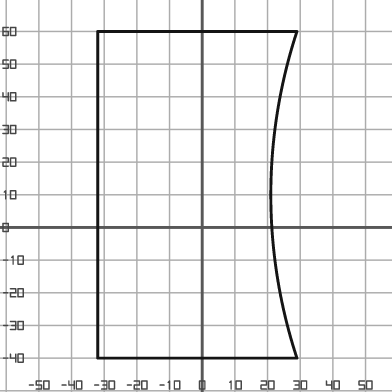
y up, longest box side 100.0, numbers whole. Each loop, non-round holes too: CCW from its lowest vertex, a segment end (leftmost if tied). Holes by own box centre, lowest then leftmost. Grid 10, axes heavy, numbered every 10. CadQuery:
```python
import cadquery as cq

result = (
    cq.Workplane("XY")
    .moveTo(-32.0, -40.0)
    .lineTo(29.0, -40.0)
    .threePointArc((21.0, 10.0), (29.0, 60.0))
    .lineTo(-32.0, 60.0)
    .close()
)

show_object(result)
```